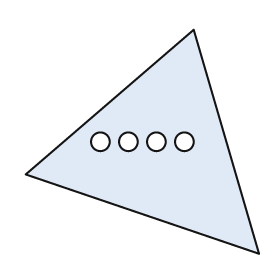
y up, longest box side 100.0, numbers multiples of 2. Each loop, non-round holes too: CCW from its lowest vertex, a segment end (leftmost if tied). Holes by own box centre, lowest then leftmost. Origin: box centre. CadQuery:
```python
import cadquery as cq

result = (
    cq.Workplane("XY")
    .moveTo(50.0, -48.0)
    .lineTo(22.0, 48.0)
    .lineTo(-50.0, -14.0)
    .close()
    .moveTo(-18.0, 0.0)
    .circle(4.0)
    .moveTo(-6.0, 0.0)
    .circle(4.0)
    .moveTo(6.0, 0.0)
    .circle(4.0)
    .moveTo(18.0, 0.0)
    .circle(4.0)
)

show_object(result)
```